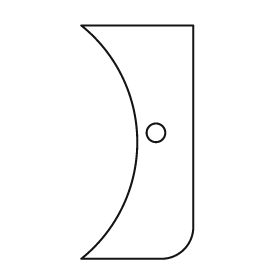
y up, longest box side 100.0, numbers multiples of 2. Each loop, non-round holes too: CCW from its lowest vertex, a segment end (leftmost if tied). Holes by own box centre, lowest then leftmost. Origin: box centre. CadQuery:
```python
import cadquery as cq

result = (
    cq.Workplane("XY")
    .moveTo(-24.0, -50.0)
    .lineTo(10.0, -50.0)
    .threePointArc((20.0, -46.0), (24.0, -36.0))
    .lineTo(24.0, 50.0)
    .lineTo(-24.0, 50.0)
    .threePointArc((0.0, 0.0), (-24.0, -50.0))
    .close()
    .moveTo(8.0, 4.0)
    .circle(4.0)
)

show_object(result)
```